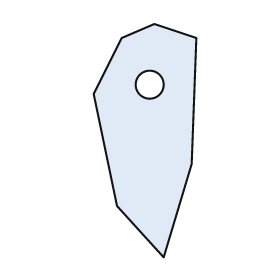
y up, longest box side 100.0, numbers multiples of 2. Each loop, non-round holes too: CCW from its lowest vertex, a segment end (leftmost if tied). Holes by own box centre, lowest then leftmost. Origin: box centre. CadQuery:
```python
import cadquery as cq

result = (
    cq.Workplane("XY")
    .moveTo(8.0, -50.0)
    .lineTo(20.0, -10.0)
    .lineTo(22.0, 44.0)
    .lineTo(4.0, 50.0)
    .lineTo(-10.0, 44.0)
    .lineTo(-22.0, 20.0)
    .lineTo(-12.0, -28.0)
    .close()
    .moveTo(2.0, 24.0)
    .circle(6.0)
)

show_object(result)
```